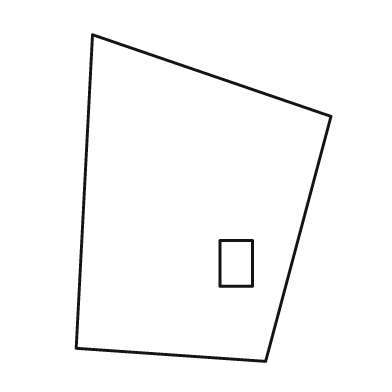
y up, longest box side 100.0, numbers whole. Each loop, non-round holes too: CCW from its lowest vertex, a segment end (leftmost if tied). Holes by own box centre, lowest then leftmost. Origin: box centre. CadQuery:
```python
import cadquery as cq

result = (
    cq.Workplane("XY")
    .moveTo(19.0, -50.0)
    .lineTo(39.0, 25.0)
    .lineTo(-34.0, 50.0)
    .lineTo(-39.0, -46.0)
    .close()
    .moveTo(5.0, -27.0)
    .lineTo(15.0, -27.0)
    .lineTo(15.0, -13.0)
    .lineTo(5.0, -13.0)
    .close()
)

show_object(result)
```